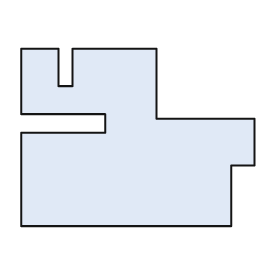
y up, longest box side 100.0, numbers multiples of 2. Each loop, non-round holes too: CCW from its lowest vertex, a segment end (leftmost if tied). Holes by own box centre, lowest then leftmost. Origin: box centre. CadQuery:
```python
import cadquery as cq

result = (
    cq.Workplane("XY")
    .moveTo(-50.0, -38.0)
    .lineTo(40.0, -38.0)
    .lineTo(40.0, -12.0)
    .lineTo(50.0, -12.0)
    .lineTo(50.0, 8.0)
    .lineTo(8.0, 8.0)
    .lineTo(8.0, 38.0)
    .lineTo(-28.0, 38.0)
    .lineTo(-28.0, 22.0)
    .lineTo(-34.0, 22.0)
    .lineTo(-34.0, 38.0)
    .lineTo(-50.0, 38.0)
    .lineTo(-50.0, 10.0)
    .lineTo(-14.0, 10.0)
    .lineTo(-14.0, 2.0)
    .lineTo(-50.0, 2.0)
    .close()
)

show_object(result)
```